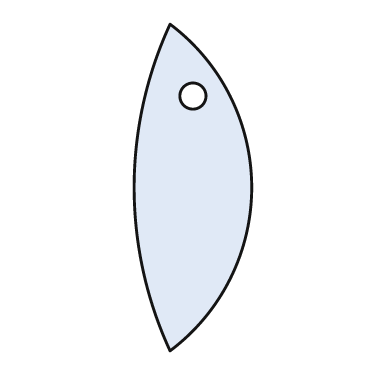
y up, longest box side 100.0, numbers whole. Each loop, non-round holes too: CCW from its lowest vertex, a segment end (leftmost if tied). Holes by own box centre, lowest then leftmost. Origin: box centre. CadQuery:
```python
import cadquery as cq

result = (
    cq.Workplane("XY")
    .moveTo(-7.0, -50.0)
    .threePointArc((18.0, 0.0), (-7.0, 50.0))
    .threePointArc((-18.0, 0.0), (-7.0, -50.0))
    .close()
    .moveTo(0.0, 28.0)
    .circle(4.0)
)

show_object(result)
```